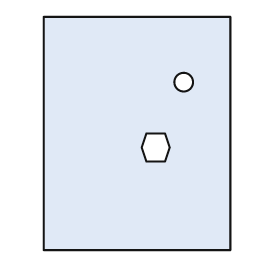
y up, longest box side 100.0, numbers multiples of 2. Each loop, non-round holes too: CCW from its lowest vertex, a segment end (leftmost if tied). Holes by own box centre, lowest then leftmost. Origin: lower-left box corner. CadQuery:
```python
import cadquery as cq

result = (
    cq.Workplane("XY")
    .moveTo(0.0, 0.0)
    .lineTo(80.0, 0.0)
    .lineTo(80.0, 100.0)
    .lineTo(0.0, 100.0)
    .close()
    .moveTo(44.0, 38.0)
    .lineTo(52.0, 38.0)
    .lineTo(54.0, 44.0)
    .lineTo(52.0, 50.0)
    .lineTo(44.0, 50.0)
    .lineTo(42.0, 44.0)
    .close()
    .moveTo(60.0, 72.0)
    .circle(4.0)
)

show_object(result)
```